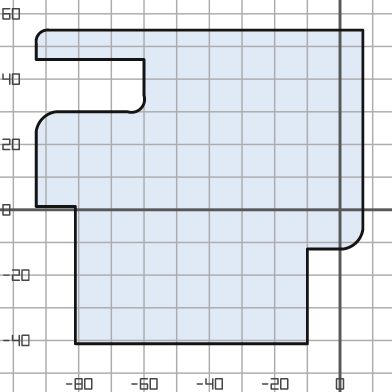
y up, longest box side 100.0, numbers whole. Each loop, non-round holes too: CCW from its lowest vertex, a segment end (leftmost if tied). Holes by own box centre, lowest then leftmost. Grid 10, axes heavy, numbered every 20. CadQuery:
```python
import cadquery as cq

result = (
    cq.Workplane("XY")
    .moveTo(-81.0, -41.0)
    .lineTo(-10.0, -41.0)
    .lineTo(-10.0, -12.0)
    .lineTo(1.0, -12.0)
    .threePointArc((5.0, -10.0), (7.0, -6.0))
    .lineTo(7.0, 55.0)
    .lineTo(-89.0, 55.0)
    .threePointArc((-92.0, 54.0), (-93.0, 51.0))
    .lineTo(-93.0, 46.0)
    .lineTo(-60.0, 46.0)
    .lineTo(-60.0, 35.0)
    .threePointArc((-61.0, 31.0), (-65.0, 30.0))
    .lineTo(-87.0, 30.0)
    .threePointArc((-91.0, 28.0), (-93.0, 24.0))
    .lineTo(-93.0, 1.0)
    .lineTo(-81.0, 1.0)
    .close()
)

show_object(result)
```